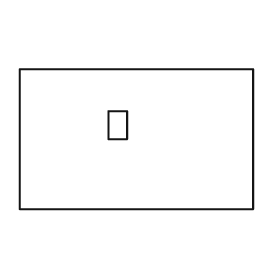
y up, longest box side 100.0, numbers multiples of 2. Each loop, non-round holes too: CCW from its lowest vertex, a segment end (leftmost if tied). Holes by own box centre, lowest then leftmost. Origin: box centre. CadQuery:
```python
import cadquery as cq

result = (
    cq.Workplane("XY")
    .moveTo(-50.0, -30.0)
    .lineTo(50.0, -30.0)
    .lineTo(50.0, 30.0)
    .lineTo(-50.0, 30.0)
    .close()
    .moveTo(-12.0, 0.0)
    .lineTo(-4.0, 0.0)
    .lineTo(-4.0, 12.0)
    .lineTo(-12.0, 12.0)
    .close()
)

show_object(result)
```